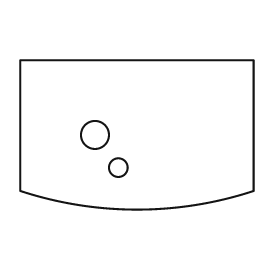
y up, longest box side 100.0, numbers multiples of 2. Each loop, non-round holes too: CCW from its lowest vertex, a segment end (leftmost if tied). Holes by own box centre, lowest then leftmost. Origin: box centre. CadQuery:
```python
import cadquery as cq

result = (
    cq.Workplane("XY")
    .moveTo(-50.0, -24.0)
    .threePointArc((0.0, -32.0), (50.0, -24.0))
    .lineTo(50.0, 32.0)
    .lineTo(-50.0, 32.0)
    .close()
    .moveTo(-8.0, -14.0)
    .circle(4.0)
    .moveTo(-18.0, 0.0)
    .circle(6.0)
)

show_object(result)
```